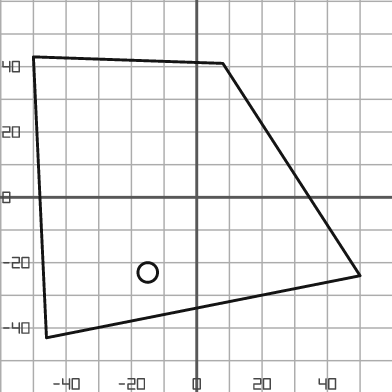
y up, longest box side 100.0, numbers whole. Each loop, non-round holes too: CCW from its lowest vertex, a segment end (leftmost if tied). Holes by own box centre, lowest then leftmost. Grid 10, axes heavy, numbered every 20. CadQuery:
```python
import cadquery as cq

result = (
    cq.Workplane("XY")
    .moveTo(-46.0, -43.0)
    .lineTo(50.0, -24.0)
    .lineTo(8.0, 41.0)
    .lineTo(-50.0, 43.0)
    .close()
    .moveTo(-15.0, -23.0)
    .circle(3.0)
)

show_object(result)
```